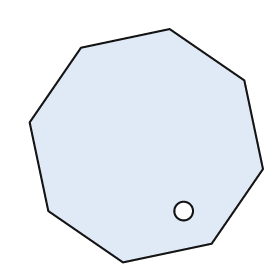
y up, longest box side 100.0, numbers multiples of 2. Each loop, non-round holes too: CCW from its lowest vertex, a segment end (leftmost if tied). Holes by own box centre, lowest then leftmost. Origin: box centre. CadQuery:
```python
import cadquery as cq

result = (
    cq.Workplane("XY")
    .moveTo(-10.0, -50.0)
    .lineTo(28.0, -42.0)
    .lineTo(50.0, -10.0)
    .lineTo(42.0, 28.0)
    .lineTo(10.0, 50.0)
    .lineTo(-28.0, 42.0)
    .lineTo(-50.0, 10.0)
    .lineTo(-42.0, -28.0)
    .close()
    .moveTo(16.0, -28.0)
    .circle(4.0)
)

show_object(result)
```